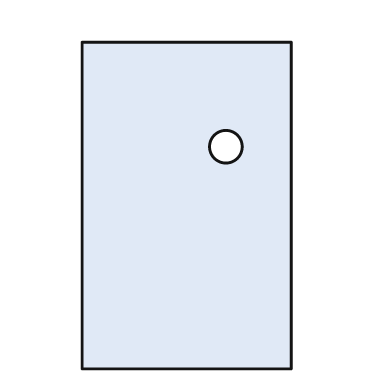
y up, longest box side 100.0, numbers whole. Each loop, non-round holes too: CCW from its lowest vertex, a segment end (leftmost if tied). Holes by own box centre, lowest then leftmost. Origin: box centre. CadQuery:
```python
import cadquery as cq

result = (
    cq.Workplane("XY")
    .moveTo(-32.0, -50.0)
    .lineTo(32.0, -50.0)
    .lineTo(32.0, 50.0)
    .lineTo(-32.0, 50.0)
    .close()
    .moveTo(12.0, 18.0)
    .circle(5.0)
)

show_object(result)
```